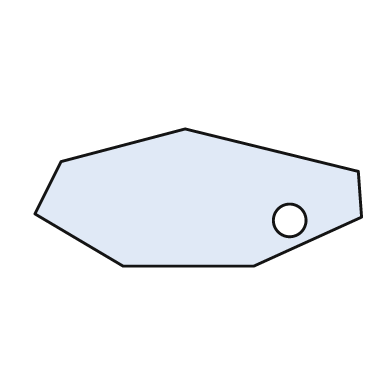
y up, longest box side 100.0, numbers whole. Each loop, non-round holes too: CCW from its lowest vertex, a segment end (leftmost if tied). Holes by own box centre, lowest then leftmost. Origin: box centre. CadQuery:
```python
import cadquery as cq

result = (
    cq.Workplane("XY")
    .moveTo(-23.0, -21.0)
    .lineTo(17.0, -21.0)
    .lineTo(50.0, -6.0)
    .lineTo(49.0, 8.0)
    .lineTo(-4.0, 21.0)
    .lineTo(-42.0, 11.0)
    .lineTo(-50.0, -5.0)
    .close()
    .moveTo(28.0, -7.0)
    .circle(5.0)
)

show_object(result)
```